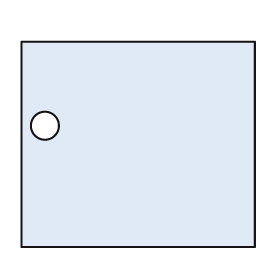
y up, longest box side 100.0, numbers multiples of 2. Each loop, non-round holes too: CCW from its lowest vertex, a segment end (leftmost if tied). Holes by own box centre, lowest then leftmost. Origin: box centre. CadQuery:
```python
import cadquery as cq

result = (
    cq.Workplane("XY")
    .moveTo(-50.0, -44.0)
    .lineTo(50.0, -44.0)
    .lineTo(50.0, 44.0)
    .lineTo(-50.0, 44.0)
    .close()
    .moveTo(-40.0, 8.0)
    .circle(6.0)
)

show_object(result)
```